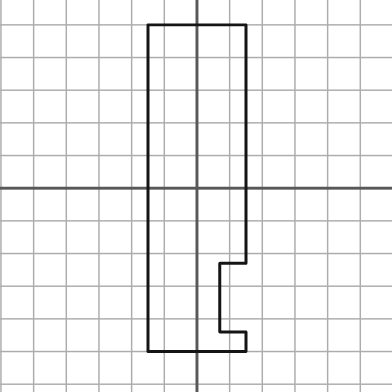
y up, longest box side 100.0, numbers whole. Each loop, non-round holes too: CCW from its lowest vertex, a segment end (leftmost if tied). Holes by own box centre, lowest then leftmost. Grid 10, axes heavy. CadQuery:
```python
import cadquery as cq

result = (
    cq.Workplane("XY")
    .moveTo(-15.0, -50.0)
    .lineTo(15.0, -50.0)
    .lineTo(15.0, -44.0)
    .lineTo(7.0, -44.0)
    .lineTo(7.0, -23.0)
    .lineTo(15.0, -23.0)
    .lineTo(15.0, 50.0)
    .lineTo(-15.0, 50.0)
    .close()
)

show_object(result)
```